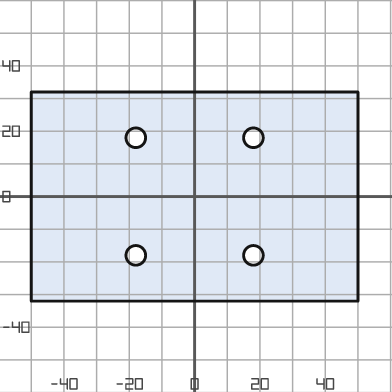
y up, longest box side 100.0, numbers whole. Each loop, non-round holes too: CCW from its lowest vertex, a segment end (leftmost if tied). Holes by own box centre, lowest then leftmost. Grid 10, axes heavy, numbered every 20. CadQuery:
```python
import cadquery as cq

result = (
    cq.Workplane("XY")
    .moveTo(-50.0, -32.0)
    .lineTo(50.0, -32.0)
    .lineTo(50.0, 32.0)
    .lineTo(-50.0, 32.0)
    .close()
    .moveTo(-18.0, -18.0)
    .circle(3.0)
    .moveTo(18.0, -18.0)
    .circle(3.0)
    .moveTo(-18.0, 18.0)
    .circle(3.0)
    .moveTo(18.0, 18.0)
    .circle(3.0)
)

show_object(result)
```